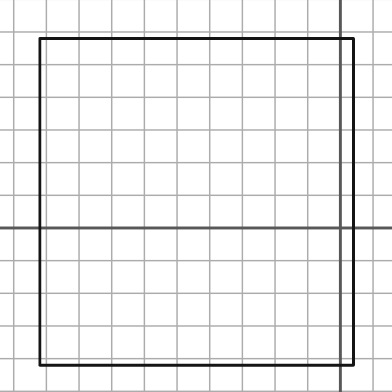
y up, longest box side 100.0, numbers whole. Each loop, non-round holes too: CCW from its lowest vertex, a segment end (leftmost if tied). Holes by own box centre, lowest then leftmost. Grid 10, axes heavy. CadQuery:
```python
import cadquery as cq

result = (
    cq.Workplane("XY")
    .moveTo(-92.0, -42.0)
    .lineTo(4.0, -42.0)
    .lineTo(4.0, 58.0)
    .lineTo(-92.0, 58.0)
    .close()
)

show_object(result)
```